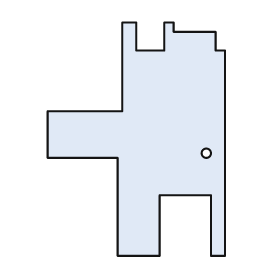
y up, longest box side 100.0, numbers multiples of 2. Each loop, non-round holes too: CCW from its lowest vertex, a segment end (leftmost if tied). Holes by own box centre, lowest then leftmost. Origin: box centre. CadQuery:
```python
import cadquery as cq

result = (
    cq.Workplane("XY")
    .moveTo(-8.0, -50.0)
    .lineTo(10.0, -50.0)
    .lineTo(10.0, -24.0)
    .lineTo(32.0, -24.0)
    .lineTo(32.0, -50.0)
    .lineTo(38.0, -50.0)
    .lineTo(38.0, 38.0)
    .lineTo(34.0, 38.0)
    .lineTo(34.0, 46.0)
    .lineTo(16.0, 46.0)
    .lineTo(16.0, 50.0)
    .lineTo(12.0, 50.0)
    .lineTo(12.0, 38.0)
    .lineTo(0.0, 38.0)
    .lineTo(0.0, 50.0)
    .lineTo(-6.0, 50.0)
    .lineTo(-6.0, 12.0)
    .lineTo(-38.0, 12.0)
    .lineTo(-38.0, -8.0)
    .lineTo(-8.0, -8.0)
    .close()
    .moveTo(30.0, -6.0)
    .circle(2.0)
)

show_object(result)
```